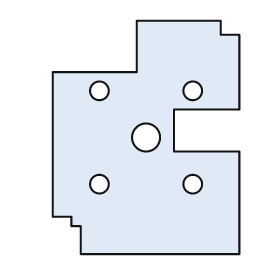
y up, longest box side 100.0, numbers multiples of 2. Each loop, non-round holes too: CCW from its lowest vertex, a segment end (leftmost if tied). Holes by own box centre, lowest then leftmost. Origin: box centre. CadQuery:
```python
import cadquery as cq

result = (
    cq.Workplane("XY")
    .moveTo(-28.0, -50.0)
    .lineTo(40.0, -50.0)
    .lineTo(40.0, -6.0)
    .lineTo(12.0, -6.0)
    .lineTo(12.0, 12.0)
    .lineTo(40.0, 12.0)
    .lineTo(40.0, 44.0)
    .lineTo(32.0, 44.0)
    .lineTo(32.0, 50.0)
    .lineTo(-4.0, 50.0)
    .lineTo(-4.0, 28.0)
    .lineTo(-40.0, 28.0)
    .lineTo(-40.0, -34.0)
    .lineTo(-32.0, -34.0)
    .lineTo(-32.0, -38.0)
    .lineTo(-28.0, -38.0)
    .close()
    .moveTo(-20.0, -20.0)
    .circle(4.0)
    .moveTo(20.0, -20.0)
    .circle(4.0)
    .moveTo(0.0, 0.0)
    .circle(6.0)
    .moveTo(-20.0, 20.0)
    .circle(4.0)
    .moveTo(20.0, 20.0)
    .circle(4.0)
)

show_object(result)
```